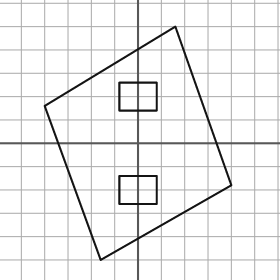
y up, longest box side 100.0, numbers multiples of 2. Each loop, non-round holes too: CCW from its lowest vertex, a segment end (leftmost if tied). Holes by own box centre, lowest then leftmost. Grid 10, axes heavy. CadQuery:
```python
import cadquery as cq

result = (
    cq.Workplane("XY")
    .moveTo(-16.0, -50.0)
    .lineTo(40.0, -18.0)
    .lineTo(16.0, 50.0)
    .lineTo(-40.0, 16.0)
    .close()
    .moveTo(-8.0, -26.0)
    .lineTo(8.0, -26.0)
    .lineTo(8.0, -14.0)
    .lineTo(-8.0, -14.0)
    .close()
    .moveTo(-8.0, 14.0)
    .lineTo(8.0, 14.0)
    .lineTo(8.0, 26.0)
    .lineTo(-8.0, 26.0)
    .close()
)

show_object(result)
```